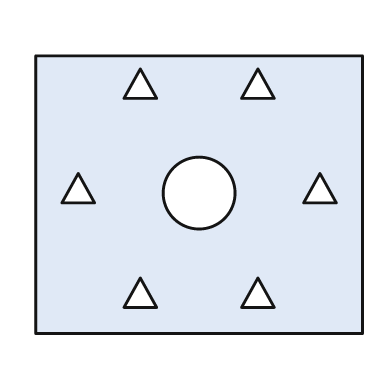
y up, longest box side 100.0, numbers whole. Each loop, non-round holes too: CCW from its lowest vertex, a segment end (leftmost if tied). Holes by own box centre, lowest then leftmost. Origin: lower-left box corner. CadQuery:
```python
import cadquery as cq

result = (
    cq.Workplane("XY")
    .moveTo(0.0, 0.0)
    .lineTo(100.0, 0.0)
    .lineTo(100.0, 85.0)
    .lineTo(0.0, 85.0)
    .close()
    .moveTo(27.0, 8.0)
    .lineTo(37.0, 8.0)
    .lineTo(32.0, 17.0)
    .close()
    .moveTo(63.0, 8.0)
    .lineTo(73.0, 8.0)
    .lineTo(68.0, 17.0)
    .close()
    .moveTo(50.0, 43.0)
    .circle(11.0)
    .moveTo(8.0, 40.0)
    .lineTo(18.0, 40.0)
    .lineTo(13.0, 49.0)
    .close()
    .moveTo(82.0, 40.0)
    .lineTo(92.0, 40.0)
    .lineTo(87.0, 49.0)
    .close()
    .moveTo(27.0, 72.0)
    .lineTo(37.0, 72.0)
    .lineTo(32.0, 81.0)
    .close()
    .moveTo(63.0, 72.0)
    .lineTo(73.0, 72.0)
    .lineTo(68.0, 81.0)
    .close()
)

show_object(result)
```